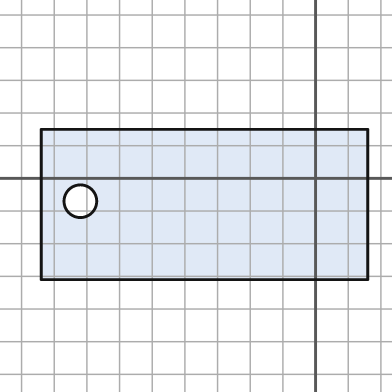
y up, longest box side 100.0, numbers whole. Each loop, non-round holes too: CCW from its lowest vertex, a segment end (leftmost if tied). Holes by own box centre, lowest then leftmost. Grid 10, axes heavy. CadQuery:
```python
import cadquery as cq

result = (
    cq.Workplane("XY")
    .moveTo(-84.0, -31.0)
    .lineTo(16.0, -31.0)
    .lineTo(16.0, 15.0)
    .lineTo(-84.0, 15.0)
    .close()
    .moveTo(-72.0, -7.0)
    .circle(5.0)
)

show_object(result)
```